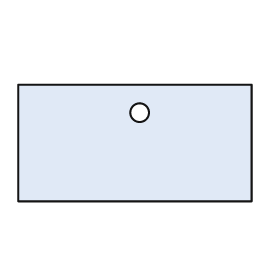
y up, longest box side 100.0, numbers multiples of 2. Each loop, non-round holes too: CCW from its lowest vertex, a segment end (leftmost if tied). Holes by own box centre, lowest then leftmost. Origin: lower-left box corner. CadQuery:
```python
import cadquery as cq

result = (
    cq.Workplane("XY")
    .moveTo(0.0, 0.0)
    .lineTo(100.0, 0.0)
    .lineTo(100.0, 50.0)
    .lineTo(0.0, 50.0)
    .close()
    .moveTo(52.0, 38.0)
    .circle(4.0)
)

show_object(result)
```